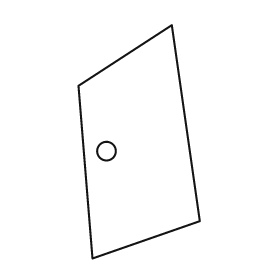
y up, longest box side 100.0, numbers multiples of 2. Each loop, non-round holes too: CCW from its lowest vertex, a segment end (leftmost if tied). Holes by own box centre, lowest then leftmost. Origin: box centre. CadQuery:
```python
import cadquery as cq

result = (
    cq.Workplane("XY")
    .moveTo(-20.0, -50.0)
    .lineTo(26.0, -34.0)
    .lineTo(14.0, 50.0)
    .lineTo(-26.0, 24.0)
    .close()
    .moveTo(-14.0, -4.0)
    .circle(4.0)
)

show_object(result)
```